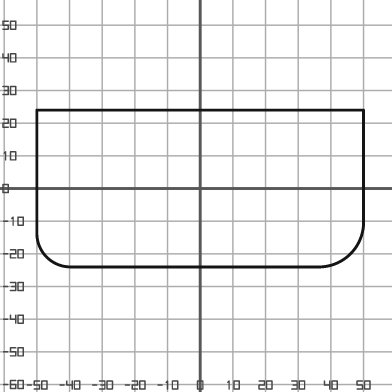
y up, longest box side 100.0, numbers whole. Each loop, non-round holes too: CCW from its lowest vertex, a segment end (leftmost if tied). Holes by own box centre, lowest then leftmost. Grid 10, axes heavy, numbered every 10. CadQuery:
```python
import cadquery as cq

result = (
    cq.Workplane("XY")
    .moveTo(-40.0, -24.0)
    .lineTo(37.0, -24.0)
    .threePointArc((46.0, -20.0), (50.0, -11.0))
    .lineTo(50.0, 24.0)
    .lineTo(-50.0, 24.0)
    .lineTo(-50.0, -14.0)
    .threePointArc((-47.0, -21.0), (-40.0, -24.0))
    .close()
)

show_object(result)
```